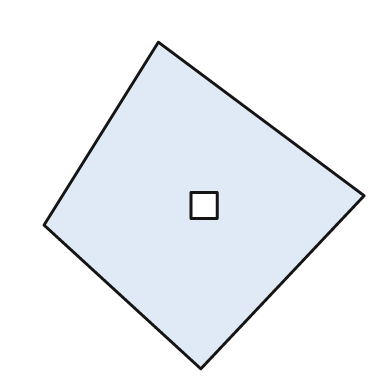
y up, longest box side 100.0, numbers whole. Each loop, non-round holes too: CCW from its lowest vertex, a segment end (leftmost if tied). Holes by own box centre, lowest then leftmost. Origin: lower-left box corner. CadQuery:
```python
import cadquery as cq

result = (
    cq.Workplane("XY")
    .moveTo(48.0, 0.0)
    .lineTo(98.0, 53.0)
    .lineTo(35.0, 100.0)
    .lineTo(0.0, 44.0)
    .close()
    .moveTo(45.0, 46.0)
    .lineTo(53.0, 46.0)
    .lineTo(53.0, 54.0)
    .lineTo(45.0, 54.0)
    .close()
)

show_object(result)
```